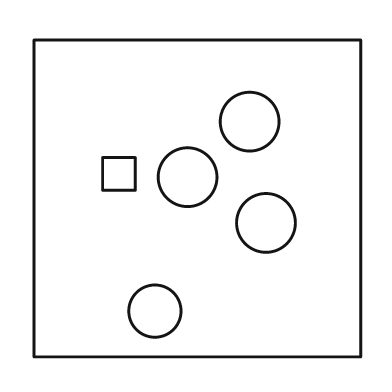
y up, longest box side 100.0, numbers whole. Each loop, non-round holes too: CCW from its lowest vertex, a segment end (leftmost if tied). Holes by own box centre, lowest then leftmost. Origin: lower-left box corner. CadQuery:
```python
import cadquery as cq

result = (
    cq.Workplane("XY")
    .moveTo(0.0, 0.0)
    .lineTo(100.0, 0.0)
    .lineTo(100.0, 97.0)
    .lineTo(0.0, 97.0)
    .close()
    .moveTo(37.0, 14.0)
    .circle(8.0)
    .moveTo(71.0, 41.0)
    .circle(9.0)
    .moveTo(47.0, 55.0)
    .circle(9.0)
    .moveTo(21.0, 51.0)
    .lineTo(31.0, 51.0)
    .lineTo(31.0, 61.0)
    .lineTo(21.0, 61.0)
    .close()
    .moveTo(66.0, 72.0)
    .circle(9.0)
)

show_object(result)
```